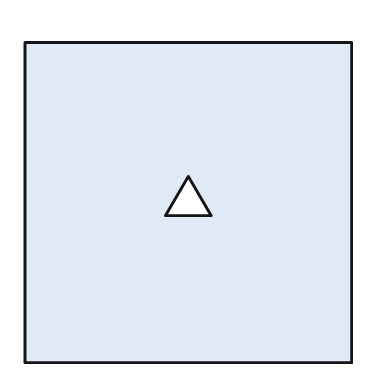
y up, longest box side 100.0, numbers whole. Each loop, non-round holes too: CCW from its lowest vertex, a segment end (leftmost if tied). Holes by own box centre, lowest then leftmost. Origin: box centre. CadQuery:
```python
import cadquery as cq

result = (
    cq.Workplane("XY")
    .moveTo(-50.0, -49.0)
    .lineTo(50.0, -49.0)
    .lineTo(50.0, 49.0)
    .lineTo(-50.0, 49.0)
    .close()
    .moveTo(-7.0, -4.0)
    .lineTo(7.0, -4.0)
    .lineTo(0.0, 8.0)
    .close()
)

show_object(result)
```